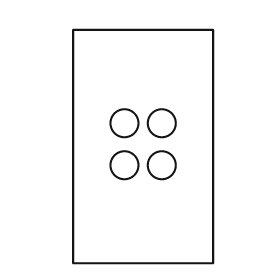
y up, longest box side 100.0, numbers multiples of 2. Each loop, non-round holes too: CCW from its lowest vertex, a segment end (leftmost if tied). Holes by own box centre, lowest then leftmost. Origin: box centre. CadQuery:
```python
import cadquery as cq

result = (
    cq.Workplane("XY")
    .moveTo(-30.0, -50.0)
    .lineTo(30.0, -50.0)
    .lineTo(30.0, 50.0)
    .lineTo(-30.0, 50.0)
    .close()
    .moveTo(-8.0, -8.0)
    .circle(6.0)
    .moveTo(8.0, -8.0)
    .circle(6.0)
    .moveTo(-8.0, 10.0)
    .circle(6.0)
    .moveTo(8.0, 10.0)
    .circle(6.0)
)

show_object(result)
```